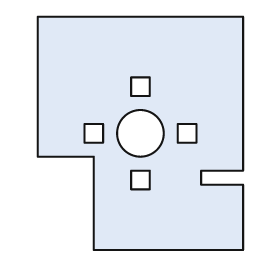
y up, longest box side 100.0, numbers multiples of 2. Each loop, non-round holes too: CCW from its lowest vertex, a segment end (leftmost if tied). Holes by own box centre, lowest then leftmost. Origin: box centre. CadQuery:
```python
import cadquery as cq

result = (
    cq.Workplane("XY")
    .moveTo(-20.0, -50.0)
    .lineTo(44.0, -50.0)
    .lineTo(44.0, -22.0)
    .lineTo(26.0, -22.0)
    .lineTo(26.0, -16.0)
    .lineTo(44.0, -16.0)
    .lineTo(44.0, 50.0)
    .lineTo(-44.0, 50.0)
    .lineTo(-44.0, -10.0)
    .lineTo(-20.0, -10.0)
    .close()
    .moveTo(-4.0, -24.0)
    .lineTo(4.0, -24.0)
    .lineTo(4.0, -16.0)
    .lineTo(-4.0, -16.0)
    .close()
    .moveTo(-24.0, -4.0)
    .lineTo(-16.0, -4.0)
    .lineTo(-16.0, 4.0)
    .lineTo(-24.0, 4.0)
    .close()
    .moveTo(0.0, 0.0)
    .circle(10.0)
    .moveTo(16.0, -4.0)
    .lineTo(24.0, -4.0)
    .lineTo(24.0, 4.0)
    .lineTo(16.0, 4.0)
    .close()
    .moveTo(-4.0, 16.0)
    .lineTo(4.0, 16.0)
    .lineTo(4.0, 24.0)
    .lineTo(-4.0, 24.0)
    .close()
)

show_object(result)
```